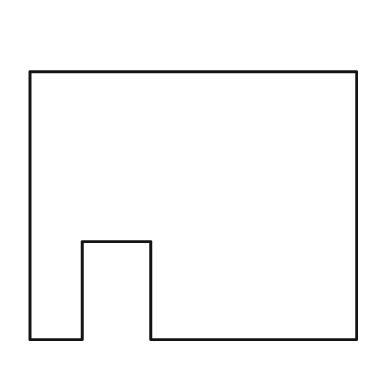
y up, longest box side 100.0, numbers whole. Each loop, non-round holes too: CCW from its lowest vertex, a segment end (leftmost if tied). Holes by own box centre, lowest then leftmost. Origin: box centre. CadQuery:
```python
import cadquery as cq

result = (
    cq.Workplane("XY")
    .moveTo(-50.0, -41.0)
    .lineTo(-34.0, -41.0)
    .lineTo(-34.0, -11.0)
    .lineTo(-13.0, -11.0)
    .lineTo(-13.0, -41.0)
    .lineTo(50.0, -41.0)
    .lineTo(50.0, 41.0)
    .lineTo(-50.0, 41.0)
    .close()
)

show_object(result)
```